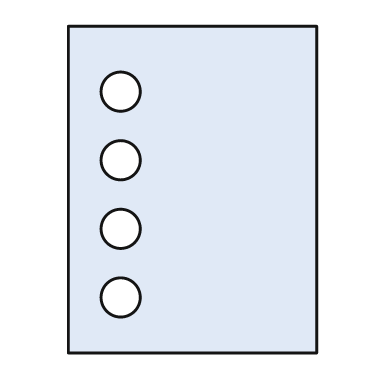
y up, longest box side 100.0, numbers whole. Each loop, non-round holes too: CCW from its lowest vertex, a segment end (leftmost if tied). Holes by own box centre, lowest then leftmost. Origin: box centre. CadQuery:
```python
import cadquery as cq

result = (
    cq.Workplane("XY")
    .moveTo(-38.0, -50.0)
    .lineTo(38.0, -50.0)
    .lineTo(38.0, 50.0)
    .lineTo(-38.0, 50.0)
    .close()
    .moveTo(-22.0, -33.0)
    .circle(6.0)
    .moveTo(-22.0, -12.0)
    .circle(6.0)
    .moveTo(-22.0, 9.0)
    .circle(6.0)
    .moveTo(-22.0, 30.0)
    .circle(6.0)
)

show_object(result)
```